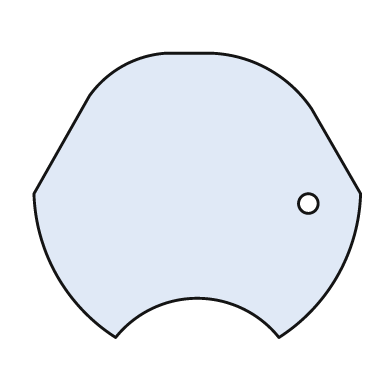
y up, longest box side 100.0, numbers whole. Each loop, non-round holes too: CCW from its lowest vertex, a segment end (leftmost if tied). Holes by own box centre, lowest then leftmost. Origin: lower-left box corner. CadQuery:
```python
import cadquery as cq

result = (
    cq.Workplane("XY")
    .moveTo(25.0, 0.0)
    .threePointArc((50.0, 12.0), (75.0, 0.0))
    .threePointArc((93.0, 19.0), (100.0, 44.0))
    .lineTo(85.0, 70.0)
    .threePointArc((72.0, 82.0), (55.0, 87.0))
    .lineTo(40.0, 87.0)
    .threePointArc((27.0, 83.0), (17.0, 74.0))
    .lineTo(0.0, 44.0)
    .threePointArc((7.0, 19.0), (25.0, 0.0))
    .close()
    .moveTo(84.0, 41.0)
    .circle(3.0)
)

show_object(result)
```